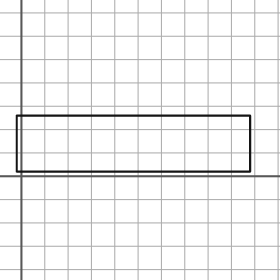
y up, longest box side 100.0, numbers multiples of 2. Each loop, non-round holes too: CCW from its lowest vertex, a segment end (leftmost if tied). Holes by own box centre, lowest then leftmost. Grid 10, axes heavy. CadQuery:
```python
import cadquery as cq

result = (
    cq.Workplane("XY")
    .moveTo(-2.0, 2.0)
    .lineTo(98.0, 2.0)
    .lineTo(98.0, 26.0)
    .lineTo(-2.0, 26.0)
    .close()
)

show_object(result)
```